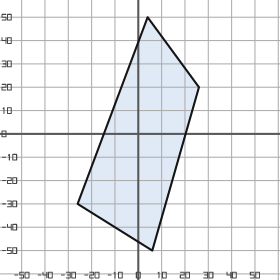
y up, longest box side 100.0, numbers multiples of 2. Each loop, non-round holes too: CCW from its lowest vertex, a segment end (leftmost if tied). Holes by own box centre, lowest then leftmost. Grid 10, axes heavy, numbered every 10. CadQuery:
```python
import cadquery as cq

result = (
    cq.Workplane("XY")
    .moveTo(6.0, -50.0)
    .lineTo(26.0, 20.0)
    .lineTo(4.0, 50.0)
    .lineTo(-26.0, -30.0)
    .close()
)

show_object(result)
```